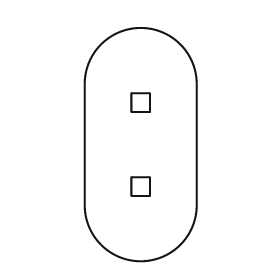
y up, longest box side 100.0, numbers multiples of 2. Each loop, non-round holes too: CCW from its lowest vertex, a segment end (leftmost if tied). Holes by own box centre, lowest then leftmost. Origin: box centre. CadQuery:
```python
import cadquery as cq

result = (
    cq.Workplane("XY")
    .moveTo(-24.0, -26.0)
    .threePointArc((0.0, -50.0), (24.0, -26.0))
    .lineTo(24.0, 26.0)
    .threePointArc((0.0, 50.0), (-24.0, 26.0))
    .close()
    .moveTo(-4.0, -22.0)
    .lineTo(4.0, -22.0)
    .lineTo(4.0, -14.0)
    .lineTo(-4.0, -14.0)
    .close()
    .moveTo(-4.0, 14.0)
    .lineTo(4.0, 14.0)
    .lineTo(4.0, 22.0)
    .lineTo(-4.0, 22.0)
    .close()
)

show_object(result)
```